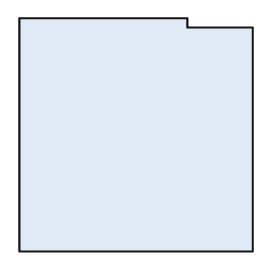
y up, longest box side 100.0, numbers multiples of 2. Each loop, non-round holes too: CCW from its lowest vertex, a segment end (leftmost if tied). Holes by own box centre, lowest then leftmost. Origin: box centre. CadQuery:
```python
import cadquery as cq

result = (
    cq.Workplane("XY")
    .moveTo(-50.0, -50.0)
    .lineTo(50.0, -50.0)
    .lineTo(50.0, 46.0)
    .lineTo(22.0, 46.0)
    .lineTo(22.0, 50.0)
    .lineTo(-50.0, 50.0)
    .close()
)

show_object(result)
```